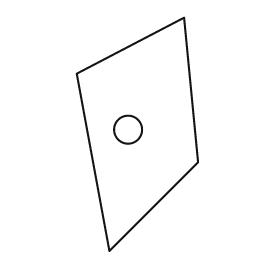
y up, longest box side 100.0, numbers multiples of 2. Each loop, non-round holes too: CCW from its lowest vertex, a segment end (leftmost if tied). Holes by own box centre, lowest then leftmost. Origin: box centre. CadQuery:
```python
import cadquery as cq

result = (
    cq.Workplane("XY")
    .moveTo(-12.0, -50.0)
    .lineTo(26.0, -12.0)
    .lineTo(20.0, 50.0)
    .lineTo(-26.0, 26.0)
    .close()
    .moveTo(-4.0, 2.0)
    .circle(6.0)
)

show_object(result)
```